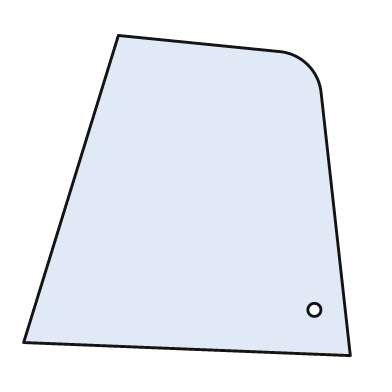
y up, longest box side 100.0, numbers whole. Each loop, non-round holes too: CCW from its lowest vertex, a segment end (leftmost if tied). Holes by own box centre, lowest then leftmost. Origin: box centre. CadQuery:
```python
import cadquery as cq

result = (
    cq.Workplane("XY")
    .moveTo(50.0, -49.0)
    .lineTo(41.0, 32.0)
    .threePointArc((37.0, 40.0), (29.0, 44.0))
    .lineTo(-21.0, 49.0)
    .lineTo(-50.0, -45.0)
    .close()
    .moveTo(39.0, -35.0)
    .circle(2.0)
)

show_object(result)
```